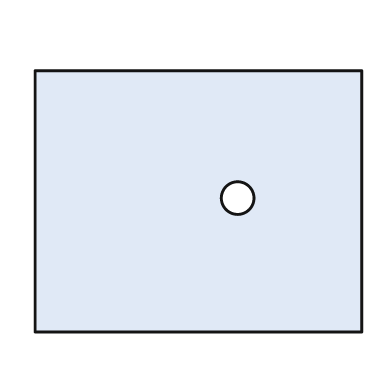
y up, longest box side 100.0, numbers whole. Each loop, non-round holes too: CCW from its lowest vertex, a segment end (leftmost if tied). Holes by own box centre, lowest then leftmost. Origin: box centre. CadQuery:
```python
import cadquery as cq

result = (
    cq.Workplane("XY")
    .moveTo(-50.0, -40.0)
    .lineTo(50.0, -40.0)
    .lineTo(50.0, 40.0)
    .lineTo(-50.0, 40.0)
    .close()
    .moveTo(12.0, 1.0)
    .circle(5.0)
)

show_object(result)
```